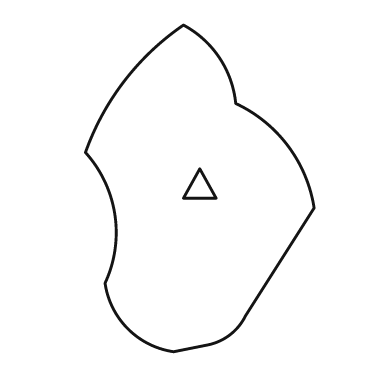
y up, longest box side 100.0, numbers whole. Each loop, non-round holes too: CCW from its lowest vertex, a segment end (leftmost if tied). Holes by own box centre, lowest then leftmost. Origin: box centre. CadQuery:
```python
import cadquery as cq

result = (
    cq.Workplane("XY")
    .moveTo(-8.0, -50.0)
    .lineTo(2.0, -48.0)
    .threePointArc((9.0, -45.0), (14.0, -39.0))
    .lineTo(35.0, -6.0)
    .threePointArc((27.0, 13.0), (11.0, 26.0))
    .threePointArc((6.0, 40.0), (-5.0, 50.0))
    .threePointArc((-23.0, 33.0), (-35.0, 11.0))
    .threePointArc((-26.0, -8.0), (-29.0, -29.0))
    .threePointArc((-22.0, -43.0), (-8.0, -50.0))
    .close()
    .moveTo(-5.0, -3.0)
    .lineTo(5.0, -3.0)
    .lineTo(0.0, 6.0)
    .close()
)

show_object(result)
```